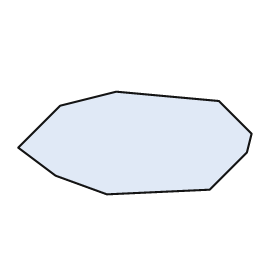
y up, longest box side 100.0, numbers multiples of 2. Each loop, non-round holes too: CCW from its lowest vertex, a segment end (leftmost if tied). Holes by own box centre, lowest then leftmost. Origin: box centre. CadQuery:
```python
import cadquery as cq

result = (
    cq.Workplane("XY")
    .moveTo(-12.0, -22.0)
    .lineTo(32.0, -20.0)
    .lineTo(48.0, -4.0)
    .lineTo(50.0, 4.0)
    .lineTo(36.0, 18.0)
    .lineTo(-8.0, 22.0)
    .lineTo(-32.0, 16.0)
    .lineTo(-50.0, -2.0)
    .lineTo(-34.0, -14.0)
    .close()
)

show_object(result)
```